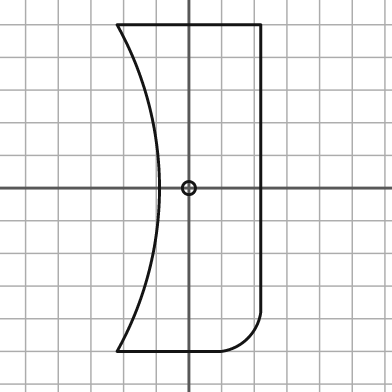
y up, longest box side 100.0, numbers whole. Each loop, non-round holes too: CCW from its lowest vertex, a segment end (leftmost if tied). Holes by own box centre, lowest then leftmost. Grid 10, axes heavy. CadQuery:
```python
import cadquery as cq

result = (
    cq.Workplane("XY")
    .moveTo(-22.0, -50.0)
    .lineTo(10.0, -50.0)
    .threePointArc((18.0, -46.0), (22.0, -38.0))
    .lineTo(22.0, 50.0)
    .lineTo(-22.0, 50.0)
    .threePointArc((-9.0, 0.0), (-22.0, -50.0))
    .close()
    .moveTo(0.0, 0.0)
    .circle(2.0)
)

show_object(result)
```